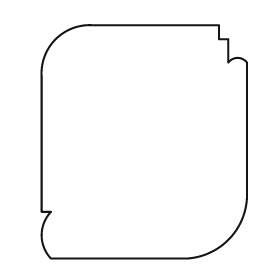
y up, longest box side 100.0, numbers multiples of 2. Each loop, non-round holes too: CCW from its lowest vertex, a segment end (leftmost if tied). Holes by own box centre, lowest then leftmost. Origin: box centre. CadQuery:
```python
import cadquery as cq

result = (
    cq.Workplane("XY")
    .moveTo(-40.0, -50.0)
    .lineTo(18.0, -50.0)
    .threePointArc((36.0, -42.0), (44.0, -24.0))
    .lineTo(44.0, 34.0)
    .threePointArc((40.0, 36.0), (36.0, 34.0))
    .lineTo(36.0, 44.0)
    .lineTo(32.0, 44.0)
    .lineTo(32.0, 50.0)
    .lineTo(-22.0, 50.0)
    .threePointArc((-38.0, 44.0), (-44.0, 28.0))
    .lineTo(-44.0, -30.0)
    .lineTo(-40.0, -30.0)
    .threePointArc((-44.0, -40.0), (-40.0, -50.0))
    .close()
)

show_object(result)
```